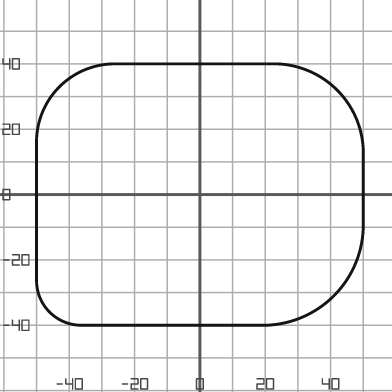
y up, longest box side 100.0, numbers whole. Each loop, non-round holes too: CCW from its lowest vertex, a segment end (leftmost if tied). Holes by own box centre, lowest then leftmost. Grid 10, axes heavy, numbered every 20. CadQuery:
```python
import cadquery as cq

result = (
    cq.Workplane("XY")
    .moveTo(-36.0, -40.0)
    .lineTo(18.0, -40.0)
    .threePointArc((41.0, -31.0), (50.0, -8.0))
    .lineTo(50.0, 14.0)
    .threePointArc((42.0, 32.0), (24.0, 40.0))
    .lineTo(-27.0, 40.0)
    .threePointArc((-43.0, 33.0), (-50.0, 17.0))
    .lineTo(-50.0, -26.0)
    .threePointArc((-46.0, -36.0), (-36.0, -40.0))
    .close()
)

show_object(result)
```